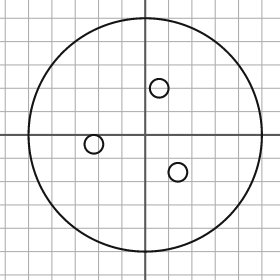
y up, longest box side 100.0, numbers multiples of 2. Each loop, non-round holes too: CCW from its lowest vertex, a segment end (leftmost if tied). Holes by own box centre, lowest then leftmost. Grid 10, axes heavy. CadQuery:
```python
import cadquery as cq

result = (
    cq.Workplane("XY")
    .moveTo(0.0, 0.0)
    .circle(50.0)
    .moveTo(14.0, -16.0)
    .circle(4.0)
    .moveTo(-22.0, -4.0)
    .circle(4.0)
    .moveTo(6.0, 20.0)
    .circle(4.0)
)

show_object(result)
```